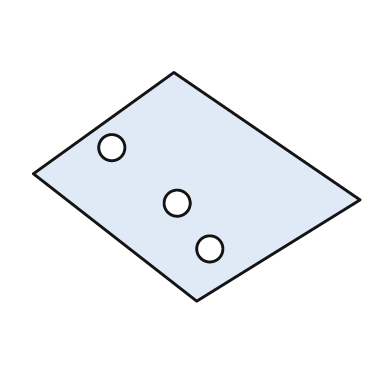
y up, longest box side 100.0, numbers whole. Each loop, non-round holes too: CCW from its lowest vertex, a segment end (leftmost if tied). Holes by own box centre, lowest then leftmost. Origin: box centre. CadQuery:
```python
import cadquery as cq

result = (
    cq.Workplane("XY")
    .moveTo(0.0, -35.0)
    .lineTo(50.0, -4.0)
    .lineTo(-7.0, 35.0)
    .lineTo(-50.0, 4.0)
    .close()
    .moveTo(4.0, -19.0)
    .circle(4.0)
    .moveTo(-6.0, -5.0)
    .circle(4.0)
    .moveTo(-26.0, 12.0)
    .circle(4.0)
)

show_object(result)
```